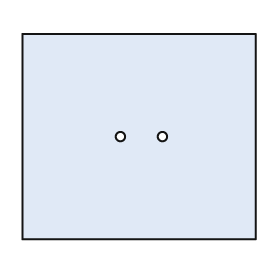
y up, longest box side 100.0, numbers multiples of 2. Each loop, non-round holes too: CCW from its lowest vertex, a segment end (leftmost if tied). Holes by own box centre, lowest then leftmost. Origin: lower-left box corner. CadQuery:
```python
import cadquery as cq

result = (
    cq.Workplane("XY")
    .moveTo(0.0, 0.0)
    .lineTo(100.0, 0.0)
    .lineTo(100.0, 88.0)
    .lineTo(0.0, 88.0)
    .close()
    .moveTo(42.0, 44.0)
    .circle(2.0)
    .moveTo(60.0, 44.0)
    .circle(2.0)
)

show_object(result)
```